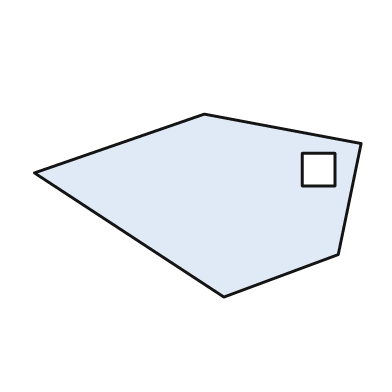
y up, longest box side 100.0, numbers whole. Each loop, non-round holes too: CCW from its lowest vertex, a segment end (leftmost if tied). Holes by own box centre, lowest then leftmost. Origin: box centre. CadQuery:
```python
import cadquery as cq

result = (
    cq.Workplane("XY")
    .moveTo(8.0, -28.0)
    .lineTo(43.0, -15.0)
    .lineTo(50.0, 19.0)
    .lineTo(2.0, 28.0)
    .lineTo(-50.0, 10.0)
    .close()
    .moveTo(32.0, 6.0)
    .lineTo(42.0, 6.0)
    .lineTo(42.0, 16.0)
    .lineTo(32.0, 16.0)
    .close()
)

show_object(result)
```